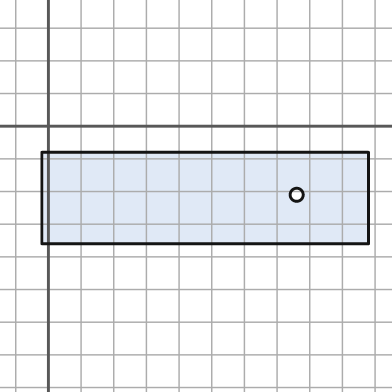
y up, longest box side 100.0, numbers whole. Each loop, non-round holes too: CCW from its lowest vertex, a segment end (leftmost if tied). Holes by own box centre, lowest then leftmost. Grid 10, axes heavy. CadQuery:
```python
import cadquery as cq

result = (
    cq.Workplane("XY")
    .moveTo(-2.0, -36.0)
    .lineTo(98.0, -36.0)
    .lineTo(98.0, -8.0)
    .lineTo(-2.0, -8.0)
    .close()
    .moveTo(76.0, -21.0)
    .circle(2.0)
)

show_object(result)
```